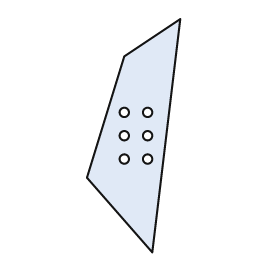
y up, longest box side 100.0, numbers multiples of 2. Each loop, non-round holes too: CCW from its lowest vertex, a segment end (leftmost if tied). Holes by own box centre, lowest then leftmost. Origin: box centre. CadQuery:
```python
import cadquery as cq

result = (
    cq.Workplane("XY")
    .moveTo(8.0, -50.0)
    .lineTo(20.0, 50.0)
    .lineTo(-4.0, 34.0)
    .lineTo(-20.0, -18.0)
    .close()
    .moveTo(-4.0, -10.0)
    .circle(2.0)
    .moveTo(6.0, -10.0)
    .circle(2.0)
    .moveTo(-4.0, 0.0)
    .circle(2.0)
    .moveTo(6.0, 0.0)
    .circle(2.0)
    .moveTo(-4.0, 10.0)
    .circle(2.0)
    .moveTo(6.0, 10.0)
    .circle(2.0)
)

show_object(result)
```